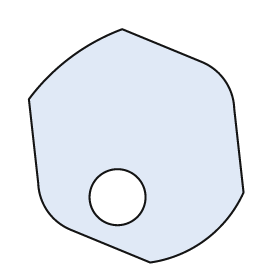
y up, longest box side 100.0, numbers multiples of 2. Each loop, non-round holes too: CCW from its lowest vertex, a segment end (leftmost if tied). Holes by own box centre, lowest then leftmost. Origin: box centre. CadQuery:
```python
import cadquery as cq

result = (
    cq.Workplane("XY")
    .moveTo(6.0, -50.0)
    .threePointArc((30.0, -40.0), (46.0, -20.0))
    .lineTo(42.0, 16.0)
    .threePointArc((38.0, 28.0), (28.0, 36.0))
    .lineTo(-6.0, 50.0)
    .threePointArc((-28.0, 38.0), (-46.0, 20.0))
    .lineTo(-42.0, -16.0)
    .threePointArc((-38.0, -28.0), (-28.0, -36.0))
    .close()
    .moveTo(-8.0, -22.0)
    .circle(12.0)
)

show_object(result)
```